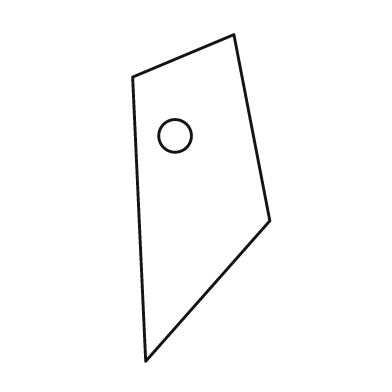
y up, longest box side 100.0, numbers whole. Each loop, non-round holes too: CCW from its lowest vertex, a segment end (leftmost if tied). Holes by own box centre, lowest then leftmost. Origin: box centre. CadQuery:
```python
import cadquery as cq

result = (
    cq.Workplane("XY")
    .moveTo(-17.0, -50.0)
    .lineTo(21.0, -7.0)
    .lineTo(10.0, 50.0)
    .lineTo(-21.0, 37.0)
    .close()
    .moveTo(-8.0, 19.0)
    .circle(5.0)
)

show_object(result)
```